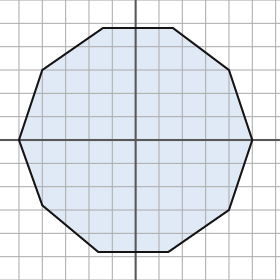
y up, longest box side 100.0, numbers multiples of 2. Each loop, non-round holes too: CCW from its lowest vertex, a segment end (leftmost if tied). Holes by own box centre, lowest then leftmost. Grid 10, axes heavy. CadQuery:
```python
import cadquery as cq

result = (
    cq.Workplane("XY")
    .moveTo(-16.0, -48.0)
    .lineTo(14.0, -48.0)
    .lineTo(40.0, -30.0)
    .lineTo(50.0, 0.0)
    .lineTo(40.0, 30.0)
    .lineTo(16.0, 48.0)
    .lineTo(-14.0, 48.0)
    .lineTo(-40.0, 30.0)
    .lineTo(-50.0, 0.0)
    .lineTo(-40.0, -28.0)
    .close()
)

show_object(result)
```